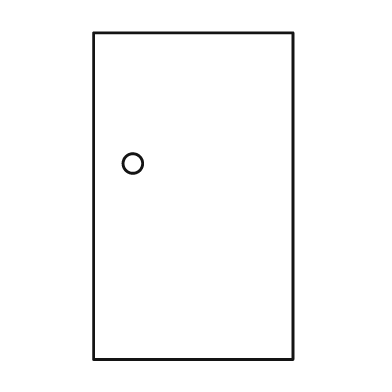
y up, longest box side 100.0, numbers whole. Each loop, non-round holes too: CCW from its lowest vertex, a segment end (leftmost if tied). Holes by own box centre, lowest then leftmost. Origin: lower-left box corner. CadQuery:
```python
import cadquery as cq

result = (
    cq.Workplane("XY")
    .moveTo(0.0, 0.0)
    .lineTo(61.0, 0.0)
    .lineTo(61.0, 100.0)
    .lineTo(0.0, 100.0)
    .close()
    .moveTo(12.0, 60.0)
    .circle(3.0)
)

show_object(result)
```